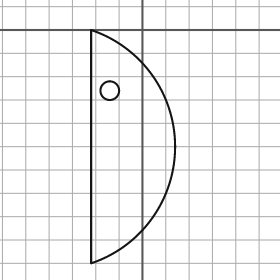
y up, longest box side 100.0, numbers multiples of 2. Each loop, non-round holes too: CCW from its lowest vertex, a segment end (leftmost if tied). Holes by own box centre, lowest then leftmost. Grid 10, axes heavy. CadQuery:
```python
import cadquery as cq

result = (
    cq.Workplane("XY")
    .moveTo(-22.0, -100.0)
    .threePointArc((14.0, -50.0), (-22.0, 0.0))
    .close()
    .moveTo(-14.0, -26.0)
    .circle(4.0)
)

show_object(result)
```